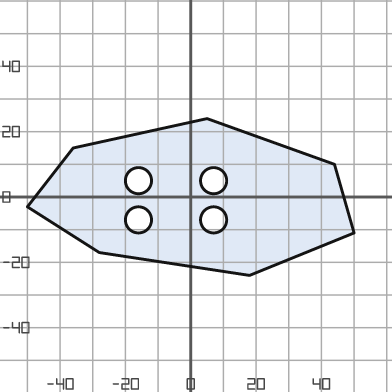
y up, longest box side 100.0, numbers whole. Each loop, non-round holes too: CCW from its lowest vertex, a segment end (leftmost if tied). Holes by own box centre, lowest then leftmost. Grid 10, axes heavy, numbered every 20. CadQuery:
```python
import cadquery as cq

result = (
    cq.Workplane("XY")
    .moveTo(18.0, -24.0)
    .lineTo(50.0, -11.0)
    .lineTo(44.0, 10.0)
    .lineTo(5.0, 24.0)
    .lineTo(-36.0, 15.0)
    .lineTo(-50.0, -3.0)
    .lineTo(-28.0, -17.0)
    .close()
    .moveTo(-16.0, -7.0)
    .circle(4.0)
    .moveTo(7.0, -7.0)
    .circle(4.0)
    .moveTo(-16.0, 5.0)
    .circle(4.0)
    .moveTo(7.0, 5.0)
    .circle(4.0)
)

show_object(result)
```